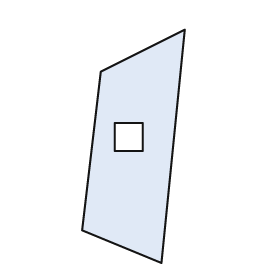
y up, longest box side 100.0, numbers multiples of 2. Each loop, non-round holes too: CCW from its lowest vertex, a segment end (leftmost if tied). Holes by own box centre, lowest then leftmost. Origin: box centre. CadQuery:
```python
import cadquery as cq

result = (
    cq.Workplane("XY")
    .moveTo(12.0, -50.0)
    .lineTo(22.0, 50.0)
    .lineTo(-14.0, 32.0)
    .lineTo(-22.0, -36.0)
    .close()
    .moveTo(-8.0, -2.0)
    .lineTo(4.0, -2.0)
    .lineTo(4.0, 10.0)
    .lineTo(-8.0, 10.0)
    .close()
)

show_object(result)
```